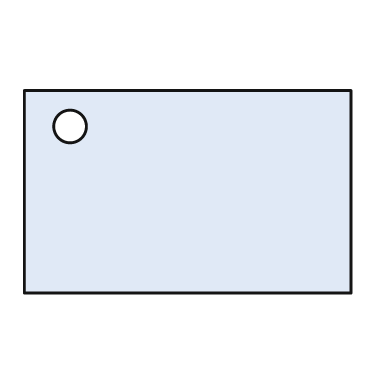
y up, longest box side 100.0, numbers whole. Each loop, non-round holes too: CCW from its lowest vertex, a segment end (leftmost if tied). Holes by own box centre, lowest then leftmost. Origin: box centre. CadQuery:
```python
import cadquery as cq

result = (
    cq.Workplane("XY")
    .moveTo(-50.0, -31.0)
    .lineTo(50.0, -31.0)
    .lineTo(50.0, 31.0)
    .lineTo(-50.0, 31.0)
    .close()
    .moveTo(-36.0, 20.0)
    .circle(5.0)
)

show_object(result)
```